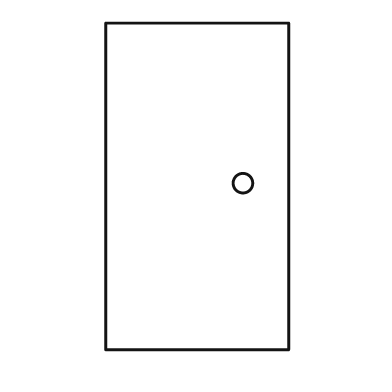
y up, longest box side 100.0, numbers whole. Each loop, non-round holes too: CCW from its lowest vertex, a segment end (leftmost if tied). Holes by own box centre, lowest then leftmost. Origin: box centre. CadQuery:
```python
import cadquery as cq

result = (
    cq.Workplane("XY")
    .moveTo(-28.0, -50.0)
    .lineTo(28.0, -50.0)
    .lineTo(28.0, 50.0)
    .lineTo(-28.0, 50.0)
    .close()
    .moveTo(14.0, 1.0)
    .circle(3.0)
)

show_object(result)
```